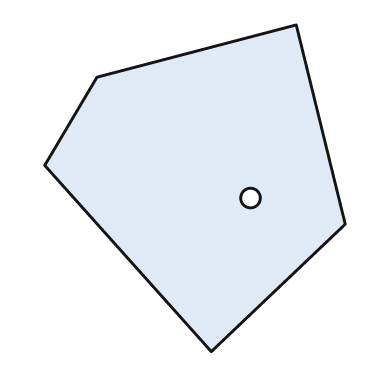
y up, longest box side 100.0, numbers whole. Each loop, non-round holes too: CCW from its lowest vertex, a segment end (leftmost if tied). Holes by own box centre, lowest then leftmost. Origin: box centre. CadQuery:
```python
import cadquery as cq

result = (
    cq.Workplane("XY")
    .moveTo(5.0, -50.0)
    .lineTo(46.0, -11.0)
    .lineTo(31.0, 50.0)
    .lineTo(-30.0, 34.0)
    .lineTo(-46.0, 7.0)
    .close()
    .moveTo(17.0, -3.0)
    .circle(3.0)
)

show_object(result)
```